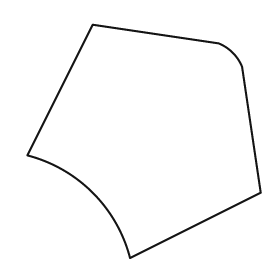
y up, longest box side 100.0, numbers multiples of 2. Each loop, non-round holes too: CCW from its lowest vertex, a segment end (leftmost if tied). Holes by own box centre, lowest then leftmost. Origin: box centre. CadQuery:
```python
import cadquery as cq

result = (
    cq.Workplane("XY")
    .moveTo(-6.0, -50.0)
    .lineTo(50.0, -22.0)
    .lineTo(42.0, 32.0)
    .threePointArc((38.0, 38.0), (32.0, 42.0))
    .lineTo(-22.0, 50.0)
    .lineTo(-50.0, -6.0)
    .threePointArc((-22.0, -22.0), (-6.0, -50.0))
    .close()
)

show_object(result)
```